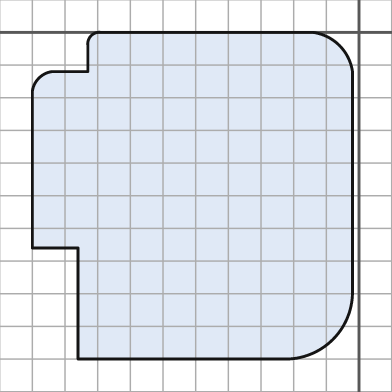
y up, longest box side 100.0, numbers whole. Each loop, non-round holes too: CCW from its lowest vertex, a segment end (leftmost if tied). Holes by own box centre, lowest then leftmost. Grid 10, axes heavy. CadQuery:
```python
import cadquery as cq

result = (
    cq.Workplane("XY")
    .moveTo(-86.0, -100.0)
    .lineTo(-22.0, -100.0)
    .threePointArc((-8.0, -94.0), (-2.0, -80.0))
    .lineTo(-2.0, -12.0)
    .threePointArc((-6.0, -4.0), (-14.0, 0.0))
    .lineTo(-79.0, 0.0)
    .threePointArc((-82.0, -1.0), (-83.0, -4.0))
    .lineTo(-83.0, -12.0)
    .lineTo(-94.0, -12.0)
    .threePointArc((-98.0, -14.0), (-100.0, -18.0))
    .lineTo(-100.0, -66.0)
    .lineTo(-86.0, -66.0)
    .close()
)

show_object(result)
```